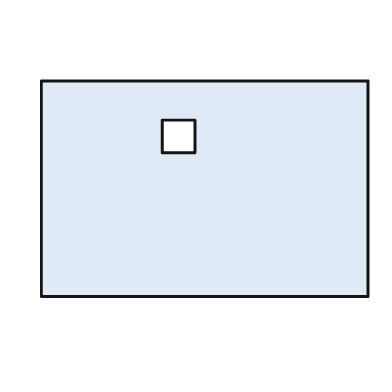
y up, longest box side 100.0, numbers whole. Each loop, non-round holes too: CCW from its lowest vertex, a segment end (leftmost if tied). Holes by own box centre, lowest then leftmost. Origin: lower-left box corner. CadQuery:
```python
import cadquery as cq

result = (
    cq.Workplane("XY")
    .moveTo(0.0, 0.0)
    .lineTo(100.0, 0.0)
    .lineTo(100.0, 66.0)
    .lineTo(0.0, 66.0)
    .close()
    .moveTo(37.0, 44.0)
    .lineTo(47.0, 44.0)
    .lineTo(47.0, 54.0)
    .lineTo(37.0, 54.0)
    .close()
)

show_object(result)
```